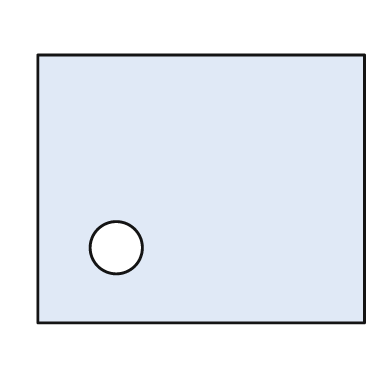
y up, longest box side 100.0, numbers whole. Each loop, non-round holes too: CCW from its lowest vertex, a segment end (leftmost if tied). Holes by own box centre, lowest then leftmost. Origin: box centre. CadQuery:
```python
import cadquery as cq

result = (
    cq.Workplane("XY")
    .moveTo(-50.0, -41.0)
    .lineTo(50.0, -41.0)
    .lineTo(50.0, 41.0)
    .lineTo(-50.0, 41.0)
    .close()
    .moveTo(-26.0, -18.0)
    .circle(8.0)
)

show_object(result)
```